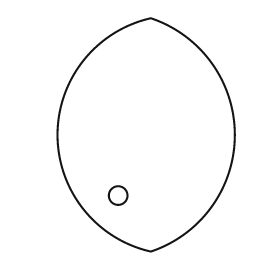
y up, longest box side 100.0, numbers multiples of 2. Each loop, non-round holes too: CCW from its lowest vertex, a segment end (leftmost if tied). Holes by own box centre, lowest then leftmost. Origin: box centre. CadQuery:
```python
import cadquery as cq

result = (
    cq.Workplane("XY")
    .moveTo(2.0, -50.0)
    .threePointArc((38.0, 0.0), (2.0, 50.0))
    .threePointArc((-38.0, 0.0), (2.0, -50.0))
    .close()
    .moveTo(-12.0, -26.0)
    .circle(4.0)
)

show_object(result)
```